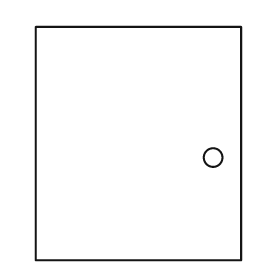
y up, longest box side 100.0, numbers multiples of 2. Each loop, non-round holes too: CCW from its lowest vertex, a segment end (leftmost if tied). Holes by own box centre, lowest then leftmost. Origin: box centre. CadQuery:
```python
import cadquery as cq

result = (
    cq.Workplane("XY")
    .moveTo(-44.0, -50.0)
    .lineTo(44.0, -50.0)
    .lineTo(44.0, 50.0)
    .lineTo(-44.0, 50.0)
    .close()
    .moveTo(32.0, -6.0)
    .circle(4.0)
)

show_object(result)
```